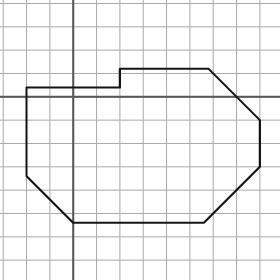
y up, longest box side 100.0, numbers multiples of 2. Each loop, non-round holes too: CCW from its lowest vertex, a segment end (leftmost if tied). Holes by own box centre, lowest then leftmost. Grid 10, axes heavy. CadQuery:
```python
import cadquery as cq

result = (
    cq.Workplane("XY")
    .moveTo(0.0, -54.0)
    .lineTo(56.0, -54.0)
    .lineTo(80.0, -30.0)
    .lineTo(80.0, -10.0)
    .lineTo(58.0, 12.0)
    .lineTo(20.0, 12.0)
    .lineTo(20.0, 4.0)
    .lineTo(-20.0, 4.0)
    .lineTo(-20.0, -34.0)
    .close()
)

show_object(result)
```